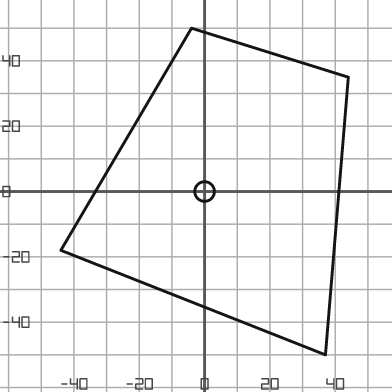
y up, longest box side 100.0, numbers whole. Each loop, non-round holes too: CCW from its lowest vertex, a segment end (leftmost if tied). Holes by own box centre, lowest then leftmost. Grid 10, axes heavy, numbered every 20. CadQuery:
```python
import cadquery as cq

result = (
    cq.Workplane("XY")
    .moveTo(37.0, -50.0)
    .lineTo(44.0, 35.0)
    .lineTo(-4.0, 50.0)
    .lineTo(-44.0, -18.0)
    .close()
    .moveTo(0.0, 0.0)
    .circle(3.0)
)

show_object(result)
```